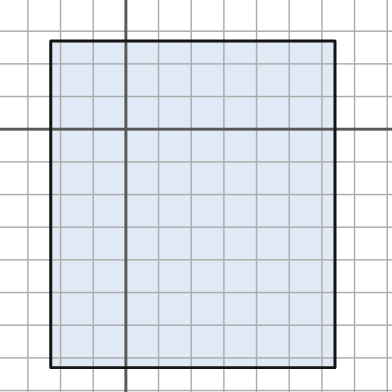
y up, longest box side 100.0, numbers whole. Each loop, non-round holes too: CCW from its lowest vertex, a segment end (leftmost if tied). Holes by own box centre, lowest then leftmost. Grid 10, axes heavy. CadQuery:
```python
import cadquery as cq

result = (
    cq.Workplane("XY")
    .moveTo(-23.0, -73.0)
    .lineTo(64.0, -73.0)
    .lineTo(64.0, 27.0)
    .lineTo(-23.0, 27.0)
    .close()
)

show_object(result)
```